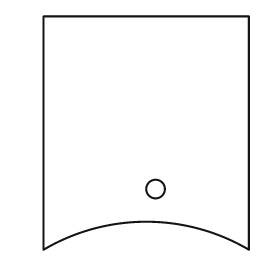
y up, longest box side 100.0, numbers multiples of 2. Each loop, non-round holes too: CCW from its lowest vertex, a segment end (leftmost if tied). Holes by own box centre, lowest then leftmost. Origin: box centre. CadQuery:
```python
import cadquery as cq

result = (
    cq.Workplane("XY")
    .moveTo(-44.0, -50.0)
    .threePointArc((0.0, -38.0), (44.0, -50.0))
    .lineTo(44.0, 50.0)
    .lineTo(-44.0, 50.0)
    .close()
    .moveTo(4.0, -24.0)
    .circle(4.0)
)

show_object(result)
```